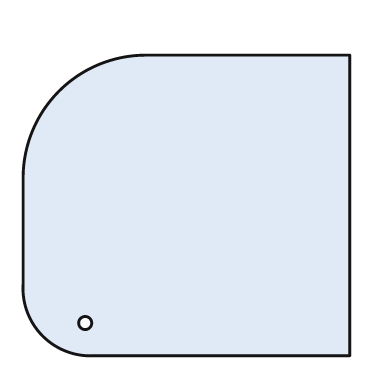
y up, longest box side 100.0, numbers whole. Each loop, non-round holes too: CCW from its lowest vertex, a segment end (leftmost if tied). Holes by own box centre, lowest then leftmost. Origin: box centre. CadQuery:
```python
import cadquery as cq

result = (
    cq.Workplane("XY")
    .moveTo(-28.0, -46.0)
    .lineTo(50.0, -46.0)
    .lineTo(50.0, 46.0)
    .lineTo(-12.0, 46.0)
    .threePointArc((-39.0, 35.0), (-50.0, 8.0))
    .lineTo(-50.0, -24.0)
    .threePointArc((-44.0, -40.0), (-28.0, -46.0))
    .close()
    .moveTo(-31.0, -36.0)
    .circle(2.0)
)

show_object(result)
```